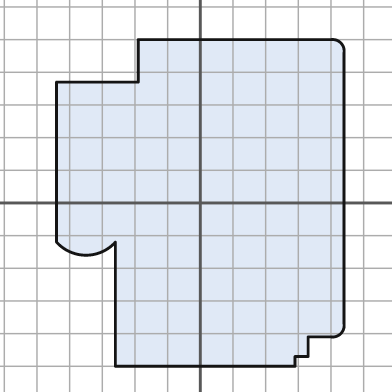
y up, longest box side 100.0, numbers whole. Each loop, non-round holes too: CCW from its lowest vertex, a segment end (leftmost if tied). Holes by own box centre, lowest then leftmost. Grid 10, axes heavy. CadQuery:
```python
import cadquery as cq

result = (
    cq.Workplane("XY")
    .moveTo(-26.0, -50.0)
    .lineTo(29.0, -50.0)
    .lineTo(29.0, -47.0)
    .lineTo(33.0, -47.0)
    .lineTo(33.0, -41.0)
    .lineTo(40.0, -41.0)
    .threePointArc((43.0, -40.0), (44.0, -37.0))
    .lineTo(44.0, 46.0)
    .threePointArc((43.0, 49.0), (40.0, 50.0))
    .lineTo(-19.0, 50.0)
    .lineTo(-19.0, 37.0)
    .lineTo(-44.0, 37.0)
    .lineTo(-44.0, -12.0)
    .threePointArc((-35.0, -16.0), (-26.0, -12.0))
    .close()
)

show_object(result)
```